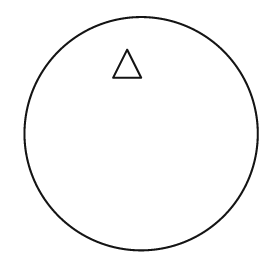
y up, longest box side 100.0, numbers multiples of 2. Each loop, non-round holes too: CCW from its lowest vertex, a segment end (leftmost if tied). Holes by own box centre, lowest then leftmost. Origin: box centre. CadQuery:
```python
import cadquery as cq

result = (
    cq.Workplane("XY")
    .moveTo(0.0, 0.0)
    .circle(50.0)
    .moveTo(-12.0, 24.0)
    .lineTo(0.0, 24.0)
    .lineTo(-6.0, 36.0)
    .close()
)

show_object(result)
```